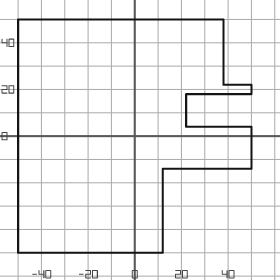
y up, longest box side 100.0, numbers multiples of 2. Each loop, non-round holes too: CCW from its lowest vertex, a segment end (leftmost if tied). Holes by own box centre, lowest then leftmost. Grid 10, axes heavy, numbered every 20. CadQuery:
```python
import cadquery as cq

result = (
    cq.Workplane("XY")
    .moveTo(-50.0, -50.0)
    .lineTo(12.0, -50.0)
    .lineTo(12.0, -14.0)
    .lineTo(50.0, -14.0)
    .lineTo(50.0, 4.0)
    .lineTo(22.0, 4.0)
    .lineTo(22.0, 18.0)
    .lineTo(50.0, 18.0)
    .lineTo(50.0, 22.0)
    .lineTo(38.0, 22.0)
    .lineTo(38.0, 50.0)
    .lineTo(-50.0, 50.0)
    .close()
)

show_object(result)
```